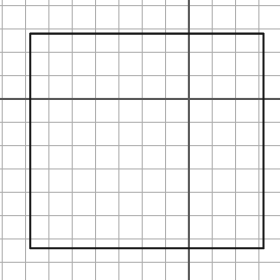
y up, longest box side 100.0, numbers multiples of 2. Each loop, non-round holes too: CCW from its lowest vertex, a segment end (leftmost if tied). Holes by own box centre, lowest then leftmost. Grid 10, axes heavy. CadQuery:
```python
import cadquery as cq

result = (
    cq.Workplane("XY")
    .moveTo(-68.0, -64.0)
    .lineTo(32.0, -64.0)
    .lineTo(32.0, 28.0)
    .lineTo(-68.0, 28.0)
    .close()
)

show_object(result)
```